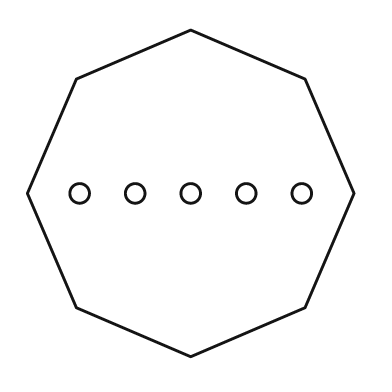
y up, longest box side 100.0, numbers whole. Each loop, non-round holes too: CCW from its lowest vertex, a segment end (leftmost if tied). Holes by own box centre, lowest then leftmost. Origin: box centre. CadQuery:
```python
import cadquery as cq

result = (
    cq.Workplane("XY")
    .moveTo(0.0, -50.0)
    .lineTo(35.0, -35.0)
    .lineTo(50.0, 0.0)
    .lineTo(35.0, 35.0)
    .lineTo(0.0, 50.0)
    .lineTo(-35.0, 35.0)
    .lineTo(-50.0, 0.0)
    .lineTo(-35.0, -35.0)
    .close()
    .moveTo(-34.0, 0.0)
    .circle(3.0)
    .moveTo(-17.0, 0.0)
    .circle(3.0)
    .moveTo(0.0, 0.0)
    .circle(3.0)
    .moveTo(17.0, 0.0)
    .circle(3.0)
    .moveTo(34.0, 0.0)
    .circle(3.0)
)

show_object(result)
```